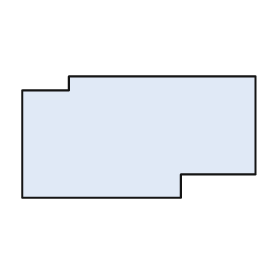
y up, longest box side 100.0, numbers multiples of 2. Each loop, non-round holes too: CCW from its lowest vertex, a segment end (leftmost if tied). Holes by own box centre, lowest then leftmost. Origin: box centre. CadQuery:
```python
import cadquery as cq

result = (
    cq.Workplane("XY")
    .moveTo(-50.0, -26.0)
    .lineTo(18.0, -26.0)
    .lineTo(18.0, -16.0)
    .lineTo(50.0, -16.0)
    .lineTo(50.0, 26.0)
    .lineTo(-30.0, 26.0)
    .lineTo(-30.0, 20.0)
    .lineTo(-50.0, 20.0)
    .close()
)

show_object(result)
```